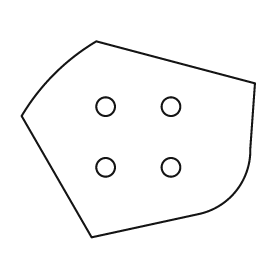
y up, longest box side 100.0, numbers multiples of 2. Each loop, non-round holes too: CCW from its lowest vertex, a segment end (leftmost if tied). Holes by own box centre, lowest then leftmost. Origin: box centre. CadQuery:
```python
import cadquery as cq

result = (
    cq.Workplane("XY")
    .moveTo(-20.0, -42.0)
    .lineTo(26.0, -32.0)
    .threePointArc((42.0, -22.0), (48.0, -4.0))
    .lineTo(50.0, 24.0)
    .lineTo(-18.0, 42.0)
    .threePointArc((-36.0, 28.0), (-50.0, 10.0))
    .close()
    .moveTo(-14.0, -12.0)
    .circle(4.0)
    .moveTo(14.0, -12.0)
    .circle(4.0)
    .moveTo(-14.0, 14.0)
    .circle(4.0)
    .moveTo(14.0, 14.0)
    .circle(4.0)
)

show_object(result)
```